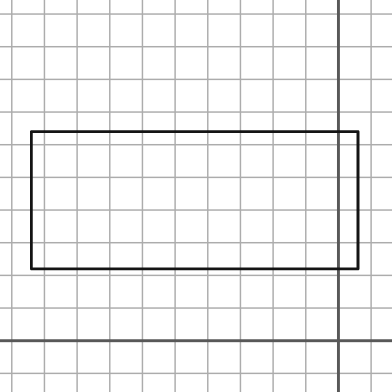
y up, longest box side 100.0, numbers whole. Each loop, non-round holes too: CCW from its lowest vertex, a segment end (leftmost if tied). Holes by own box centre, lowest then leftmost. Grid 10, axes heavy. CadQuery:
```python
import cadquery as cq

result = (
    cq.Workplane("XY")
    .moveTo(-94.0, 22.0)
    .lineTo(6.0, 22.0)
    .lineTo(6.0, 64.0)
    .lineTo(-94.0, 64.0)
    .close()
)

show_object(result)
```